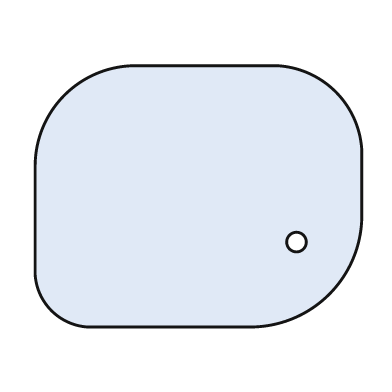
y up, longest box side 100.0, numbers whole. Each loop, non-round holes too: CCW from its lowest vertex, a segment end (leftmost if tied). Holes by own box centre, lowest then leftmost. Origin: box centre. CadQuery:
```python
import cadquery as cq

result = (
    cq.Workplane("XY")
    .moveTo(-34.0, -40.0)
    .lineTo(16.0, -40.0)
    .threePointArc((40.0, -30.0), (50.0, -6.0))
    .lineTo(50.0, 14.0)
    .threePointArc((42.0, 32.0), (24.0, 40.0))
    .lineTo(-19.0, 40.0)
    .threePointArc((-41.0, 31.0), (-50.0, 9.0))
    .lineTo(-50.0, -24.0)
    .threePointArc((-45.0, -35.0), (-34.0, -40.0))
    .close()
    .moveTo(30.0, -14.0)
    .circle(3.0)
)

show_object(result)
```